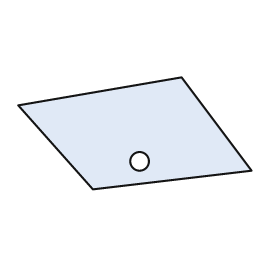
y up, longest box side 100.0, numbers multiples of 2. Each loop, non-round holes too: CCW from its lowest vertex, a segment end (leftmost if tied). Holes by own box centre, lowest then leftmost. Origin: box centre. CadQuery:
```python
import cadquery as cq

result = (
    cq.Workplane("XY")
    .moveTo(-18.0, -24.0)
    .lineTo(50.0, -16.0)
    .lineTo(20.0, 24.0)
    .lineTo(-50.0, 12.0)
    .close()
    .moveTo(2.0, -12.0)
    .circle(4.0)
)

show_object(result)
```